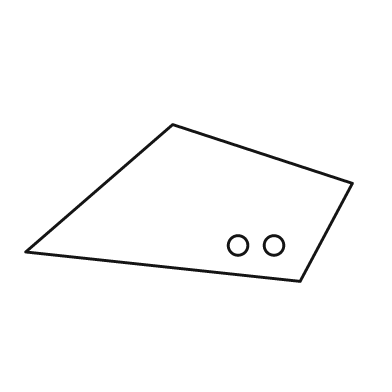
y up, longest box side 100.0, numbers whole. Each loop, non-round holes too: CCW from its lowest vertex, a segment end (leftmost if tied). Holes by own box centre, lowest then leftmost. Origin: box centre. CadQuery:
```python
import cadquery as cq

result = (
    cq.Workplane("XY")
    .moveTo(34.0, -24.0)
    .lineTo(50.0, 6.0)
    .lineTo(-5.0, 24.0)
    .lineTo(-50.0, -15.0)
    .close()
    .moveTo(15.0, -13.0)
    .circle(3.0)
    .moveTo(26.0, -13.0)
    .circle(3.0)
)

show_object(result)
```